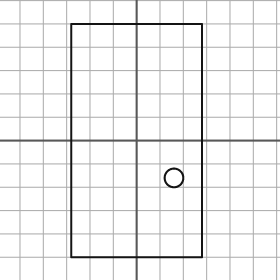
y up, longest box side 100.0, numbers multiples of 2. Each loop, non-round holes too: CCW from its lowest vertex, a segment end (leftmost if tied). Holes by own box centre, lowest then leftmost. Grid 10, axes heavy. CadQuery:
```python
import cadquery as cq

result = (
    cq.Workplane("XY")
    .moveTo(-28.0, -50.0)
    .lineTo(28.0, -50.0)
    .lineTo(28.0, 50.0)
    .lineTo(-28.0, 50.0)
    .close()
    .moveTo(16.0, -16.0)
    .circle(4.0)
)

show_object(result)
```